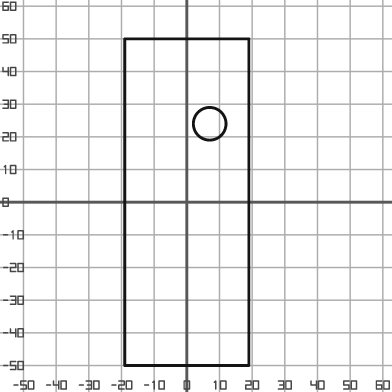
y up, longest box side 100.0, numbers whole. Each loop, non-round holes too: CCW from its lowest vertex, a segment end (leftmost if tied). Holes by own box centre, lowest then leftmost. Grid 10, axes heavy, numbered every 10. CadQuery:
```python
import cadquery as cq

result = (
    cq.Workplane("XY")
    .moveTo(-19.0, -50.0)
    .lineTo(19.0, -50.0)
    .lineTo(19.0, 50.0)
    .lineTo(-19.0, 50.0)
    .close()
    .moveTo(7.0, 24.0)
    .circle(5.0)
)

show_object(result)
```